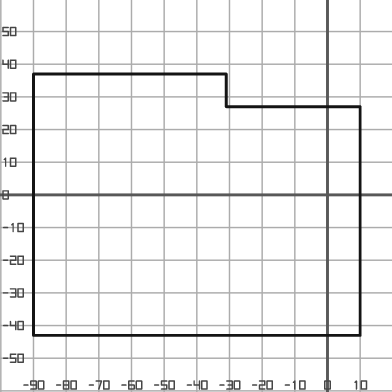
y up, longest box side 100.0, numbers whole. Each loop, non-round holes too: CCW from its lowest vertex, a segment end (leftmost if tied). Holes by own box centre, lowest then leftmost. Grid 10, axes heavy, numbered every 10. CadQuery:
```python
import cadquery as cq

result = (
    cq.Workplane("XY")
    .moveTo(-90.0, -43.0)
    .lineTo(10.0, -43.0)
    .lineTo(10.0, 27.0)
    .lineTo(-31.0, 27.0)
    .lineTo(-31.0, 37.0)
    .lineTo(-90.0, 37.0)
    .close()
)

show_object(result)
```